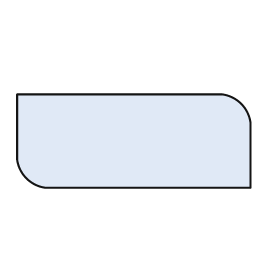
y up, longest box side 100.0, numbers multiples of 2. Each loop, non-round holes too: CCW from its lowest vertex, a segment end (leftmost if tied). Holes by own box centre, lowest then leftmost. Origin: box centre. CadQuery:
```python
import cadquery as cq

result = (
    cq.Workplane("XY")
    .moveTo(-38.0, -20.0)
    .lineTo(50.0, -20.0)
    .lineTo(50.0, 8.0)
    .threePointArc((46.0, 16.0), (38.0, 20.0))
    .lineTo(-50.0, 20.0)
    .lineTo(-50.0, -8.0)
    .threePointArc((-46.0, -16.0), (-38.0, -20.0))
    .close()
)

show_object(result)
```